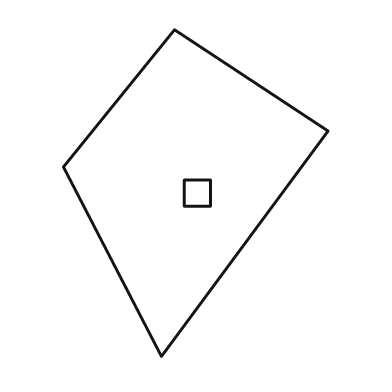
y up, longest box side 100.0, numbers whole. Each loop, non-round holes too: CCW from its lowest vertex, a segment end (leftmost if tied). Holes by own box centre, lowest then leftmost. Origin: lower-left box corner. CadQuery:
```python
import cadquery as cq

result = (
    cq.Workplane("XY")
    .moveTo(30.0, 0.0)
    .lineTo(81.0, 69.0)
    .lineTo(34.0, 100.0)
    .lineTo(0.0, 58.0)
    .close()
    .moveTo(37.0, 46.0)
    .lineTo(45.0, 46.0)
    .lineTo(45.0, 54.0)
    .lineTo(37.0, 54.0)
    .close()
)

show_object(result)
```